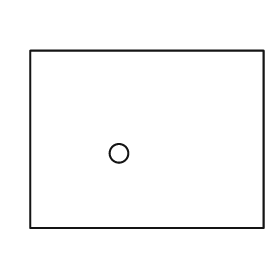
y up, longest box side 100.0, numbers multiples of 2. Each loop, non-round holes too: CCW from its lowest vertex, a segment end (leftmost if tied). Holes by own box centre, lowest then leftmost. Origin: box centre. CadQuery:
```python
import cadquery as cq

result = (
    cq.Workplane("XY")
    .moveTo(-50.0, -38.0)
    .lineTo(50.0, -38.0)
    .lineTo(50.0, 38.0)
    .lineTo(-50.0, 38.0)
    .close()
    .moveTo(-12.0, -6.0)
    .circle(4.0)
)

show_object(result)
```